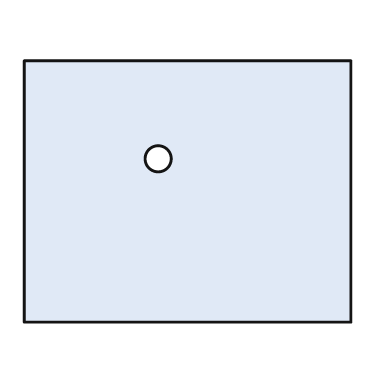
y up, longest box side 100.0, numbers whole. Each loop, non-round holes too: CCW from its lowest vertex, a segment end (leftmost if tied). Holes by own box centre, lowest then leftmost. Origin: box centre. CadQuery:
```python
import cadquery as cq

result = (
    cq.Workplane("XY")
    .moveTo(-50.0, -40.0)
    .lineTo(50.0, -40.0)
    .lineTo(50.0, 40.0)
    .lineTo(-50.0, 40.0)
    .close()
    .moveTo(-9.0, 10.0)
    .circle(4.0)
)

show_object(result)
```